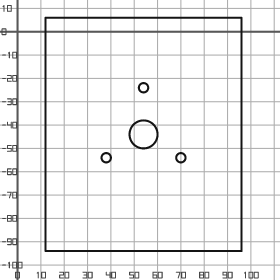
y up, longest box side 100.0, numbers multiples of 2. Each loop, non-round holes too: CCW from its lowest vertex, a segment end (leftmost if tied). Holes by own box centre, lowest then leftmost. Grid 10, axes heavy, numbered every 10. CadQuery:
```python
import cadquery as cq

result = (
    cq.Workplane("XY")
    .moveTo(12.0, -94.0)
    .lineTo(96.0, -94.0)
    .lineTo(96.0, 6.0)
    .lineTo(12.0, 6.0)
    .close()
    .moveTo(38.0, -54.0)
    .circle(2.0)
    .moveTo(70.0, -54.0)
    .circle(2.0)
    .moveTo(54.0, -44.0)
    .circle(6.0)
    .moveTo(54.0, -24.0)
    .circle(2.0)
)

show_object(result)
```